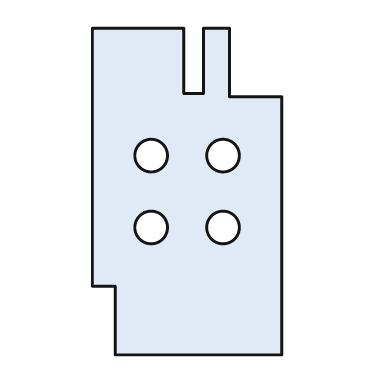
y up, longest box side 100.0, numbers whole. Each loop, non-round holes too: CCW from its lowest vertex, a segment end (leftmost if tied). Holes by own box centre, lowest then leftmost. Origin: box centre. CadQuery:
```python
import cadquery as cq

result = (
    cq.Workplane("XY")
    .moveTo(-22.0, -50.0)
    .lineTo(29.0, -50.0)
    .lineTo(29.0, 29.0)
    .lineTo(13.0, 29.0)
    .lineTo(13.0, 50.0)
    .lineTo(5.0, 50.0)
    .lineTo(5.0, 30.0)
    .lineTo(-1.0, 30.0)
    .lineTo(-1.0, 50.0)
    .lineTo(-29.0, 50.0)
    .lineTo(-29.0, -29.0)
    .lineTo(-22.0, -29.0)
    .close()
    .moveTo(-11.0, -11.0)
    .circle(5.0)
    .moveTo(11.0, -11.0)
    .circle(5.0)
    .moveTo(-11.0, 11.0)
    .circle(5.0)
    .moveTo(11.0, 11.0)
    .circle(5.0)
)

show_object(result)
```